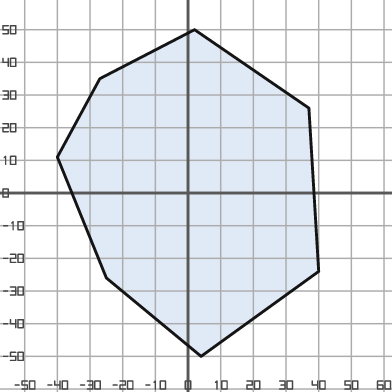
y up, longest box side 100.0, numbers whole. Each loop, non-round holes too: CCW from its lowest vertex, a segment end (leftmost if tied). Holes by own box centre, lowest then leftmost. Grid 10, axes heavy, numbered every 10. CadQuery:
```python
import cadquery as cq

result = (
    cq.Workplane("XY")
    .moveTo(4.0, -50.0)
    .lineTo(40.0, -24.0)
    .lineTo(37.0, 26.0)
    .lineTo(2.0, 50.0)
    .lineTo(-27.0, 35.0)
    .lineTo(-40.0, 11.0)
    .lineTo(-25.0, -26.0)
    .close()
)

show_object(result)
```